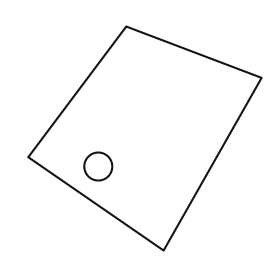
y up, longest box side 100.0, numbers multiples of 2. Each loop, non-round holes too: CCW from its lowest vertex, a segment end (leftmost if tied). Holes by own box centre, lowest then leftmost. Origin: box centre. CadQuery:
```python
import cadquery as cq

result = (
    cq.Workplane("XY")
    .moveTo(8.0, -48.0)
    .lineTo(50.0, 26.0)
    .lineTo(-8.0, 48.0)
    .lineTo(-50.0, -8.0)
    .close()
    .moveTo(-20.0, -12.0)
    .circle(6.0)
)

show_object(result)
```